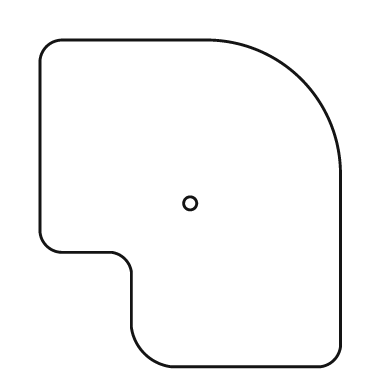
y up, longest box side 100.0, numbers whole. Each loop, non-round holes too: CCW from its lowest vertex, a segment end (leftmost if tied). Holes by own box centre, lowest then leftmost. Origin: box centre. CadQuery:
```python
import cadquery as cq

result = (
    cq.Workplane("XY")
    .moveTo(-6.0, -50.0)
    .lineTo(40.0, -50.0)
    .threePointArc((44.0, -48.0), (46.0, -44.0))
    .lineTo(46.0, 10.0)
    .threePointArc((34.0, 38.0), (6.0, 50.0))
    .lineTo(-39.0, 50.0)
    .threePointArc((-44.0, 48.0), (-46.0, 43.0))
    .lineTo(-46.0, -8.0)
    .threePointArc((-44.0, -13.0), (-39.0, -15.0))
    .lineTo(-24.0, -15.0)
    .threePointArc((-20.0, -17.0), (-18.0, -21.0))
    .lineTo(-18.0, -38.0)
    .threePointArc((-14.0, -46.0), (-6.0, -50.0))
    .close()
    .moveTo(0.0, 0.0)
    .circle(2.0)
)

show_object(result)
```